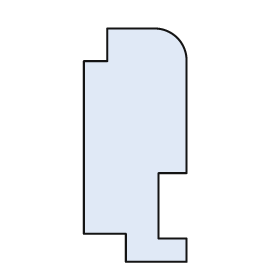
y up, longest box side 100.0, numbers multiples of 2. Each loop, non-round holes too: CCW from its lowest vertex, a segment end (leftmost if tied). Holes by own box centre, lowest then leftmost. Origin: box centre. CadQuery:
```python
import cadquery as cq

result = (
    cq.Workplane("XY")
    .moveTo(-4.0, -50.0)
    .lineTo(22.0, -50.0)
    .lineTo(22.0, -40.0)
    .lineTo(10.0, -40.0)
    .lineTo(10.0, -12.0)
    .lineTo(22.0, -12.0)
    .lineTo(22.0, 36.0)
    .threePointArc((18.0, 46.0), (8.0, 50.0))
    .lineTo(-12.0, 50.0)
    .lineTo(-12.0, 36.0)
    .lineTo(-22.0, 36.0)
    .lineTo(-22.0, -38.0)
    .lineTo(-4.0, -38.0)
    .close()
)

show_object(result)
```